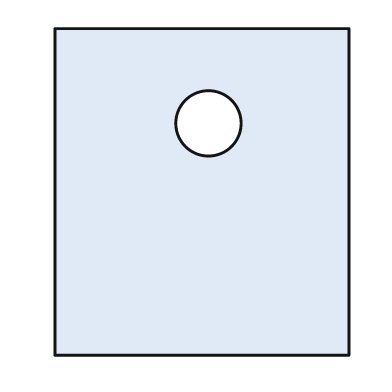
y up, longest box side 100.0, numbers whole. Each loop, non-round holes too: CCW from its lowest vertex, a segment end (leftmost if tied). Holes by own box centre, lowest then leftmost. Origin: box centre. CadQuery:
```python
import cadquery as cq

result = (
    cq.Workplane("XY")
    .moveTo(-45.0, -50.0)
    .lineTo(45.0, -50.0)
    .lineTo(45.0, 50.0)
    .lineTo(-45.0, 50.0)
    .close()
    .moveTo(2.0, 21.0)
    .circle(10.0)
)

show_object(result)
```